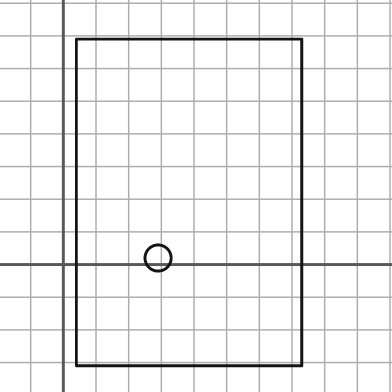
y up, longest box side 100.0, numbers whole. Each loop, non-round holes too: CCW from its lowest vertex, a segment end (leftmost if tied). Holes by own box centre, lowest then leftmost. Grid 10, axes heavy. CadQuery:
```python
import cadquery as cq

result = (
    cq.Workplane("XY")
    .moveTo(4.0, -31.0)
    .lineTo(73.0, -31.0)
    .lineTo(73.0, 69.0)
    .lineTo(4.0, 69.0)
    .close()
    .moveTo(29.0, 2.0)
    .circle(4.0)
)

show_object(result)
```